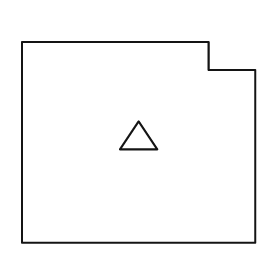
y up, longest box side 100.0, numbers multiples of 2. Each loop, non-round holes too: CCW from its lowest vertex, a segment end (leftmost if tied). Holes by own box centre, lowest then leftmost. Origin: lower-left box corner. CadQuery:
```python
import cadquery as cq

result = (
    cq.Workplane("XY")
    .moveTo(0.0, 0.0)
    .lineTo(100.0, 0.0)
    .lineTo(100.0, 74.0)
    .lineTo(80.0, 74.0)
    .lineTo(80.0, 86.0)
    .lineTo(0.0, 86.0)
    .close()
    .moveTo(42.0, 40.0)
    .lineTo(58.0, 40.0)
    .lineTo(50.0, 52.0)
    .close()
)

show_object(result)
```